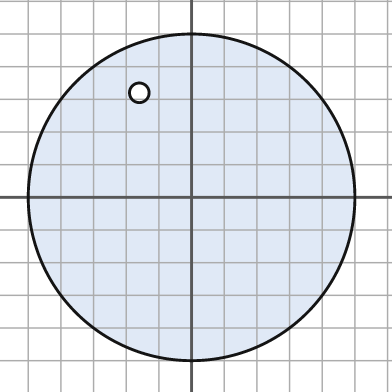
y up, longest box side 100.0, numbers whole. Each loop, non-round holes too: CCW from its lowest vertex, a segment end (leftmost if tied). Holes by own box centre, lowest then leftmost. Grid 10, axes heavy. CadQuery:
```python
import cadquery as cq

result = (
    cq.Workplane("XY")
    .moveTo(0.0, 0.0)
    .circle(50.0)
    .moveTo(-16.0, 32.0)
    .circle(3.0)
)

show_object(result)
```